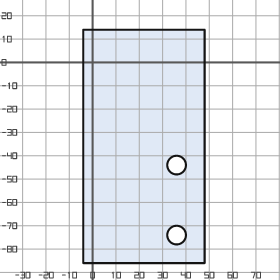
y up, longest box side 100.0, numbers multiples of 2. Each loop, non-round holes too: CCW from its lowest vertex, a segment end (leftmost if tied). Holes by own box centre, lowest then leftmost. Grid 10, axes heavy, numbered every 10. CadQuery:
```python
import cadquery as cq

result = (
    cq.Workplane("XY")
    .moveTo(-4.0, -86.0)
    .lineTo(48.0, -86.0)
    .lineTo(48.0, 14.0)
    .lineTo(-4.0, 14.0)
    .close()
    .moveTo(36.0, -74.0)
    .circle(4.0)
    .moveTo(36.0, -44.0)
    .circle(4.0)
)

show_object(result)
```